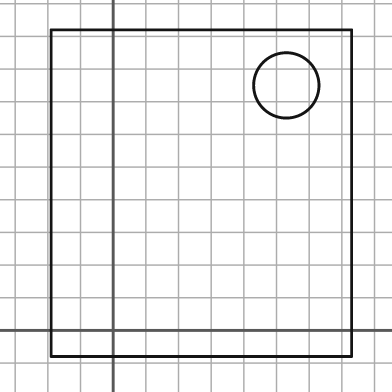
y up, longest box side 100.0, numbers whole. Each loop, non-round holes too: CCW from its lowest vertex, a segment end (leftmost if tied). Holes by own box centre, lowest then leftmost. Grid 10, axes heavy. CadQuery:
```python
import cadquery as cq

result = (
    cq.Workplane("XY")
    .moveTo(-19.0, -8.0)
    .lineTo(73.0, -8.0)
    .lineTo(73.0, 92.0)
    .lineTo(-19.0, 92.0)
    .close()
    .moveTo(53.0, 75.0)
    .circle(10.0)
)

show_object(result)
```